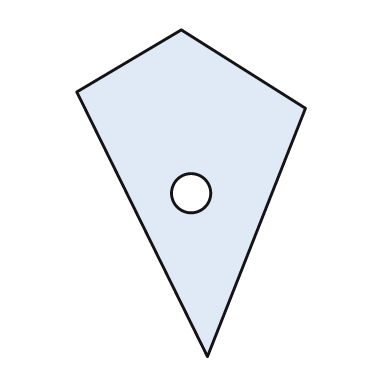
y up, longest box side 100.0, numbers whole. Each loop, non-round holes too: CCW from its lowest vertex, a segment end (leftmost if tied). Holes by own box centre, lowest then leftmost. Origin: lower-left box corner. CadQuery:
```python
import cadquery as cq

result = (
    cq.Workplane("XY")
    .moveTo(40.0, 0.0)
    .lineTo(70.0, 76.0)
    .lineTo(32.0, 100.0)
    .lineTo(0.0, 81.0)
    .close()
    .moveTo(35.0, 50.0)
    .circle(6.0)
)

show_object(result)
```